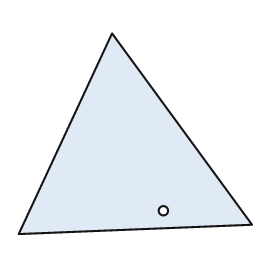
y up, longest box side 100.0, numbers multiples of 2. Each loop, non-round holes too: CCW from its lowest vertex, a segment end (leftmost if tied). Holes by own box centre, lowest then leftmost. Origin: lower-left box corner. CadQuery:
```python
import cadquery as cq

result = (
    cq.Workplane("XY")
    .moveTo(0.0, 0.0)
    .lineTo(100.0, 4.0)
    .lineTo(40.0, 86.0)
    .close()
    .moveTo(62.0, 10.0)
    .circle(2.0)
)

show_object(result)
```